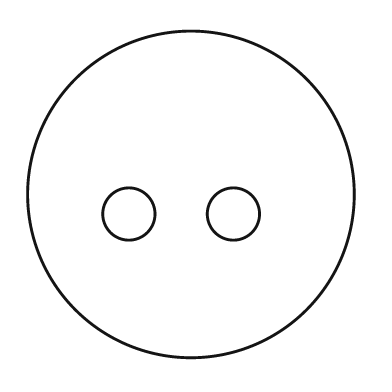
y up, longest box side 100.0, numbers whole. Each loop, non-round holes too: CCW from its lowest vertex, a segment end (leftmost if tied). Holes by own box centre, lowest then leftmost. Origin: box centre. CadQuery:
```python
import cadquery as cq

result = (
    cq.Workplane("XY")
    .moveTo(0.0, 0.0)
    .circle(50.0)
    .moveTo(-19.0, -6.0)
    .circle(8.0)
    .moveTo(13.0, -6.0)
    .circle(8.0)
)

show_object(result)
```